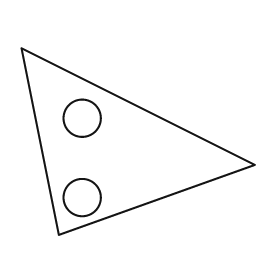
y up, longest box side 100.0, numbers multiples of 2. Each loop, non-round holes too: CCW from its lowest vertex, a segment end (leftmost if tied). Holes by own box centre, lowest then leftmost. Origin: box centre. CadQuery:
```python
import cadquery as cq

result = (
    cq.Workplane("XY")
    .moveTo(-34.0, -40.0)
    .lineTo(50.0, -10.0)
    .lineTo(-50.0, 40.0)
    .close()
    .moveTo(-24.0, -24.0)
    .circle(8.0)
    .moveTo(-24.0, 10.0)
    .circle(8.0)
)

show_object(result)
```